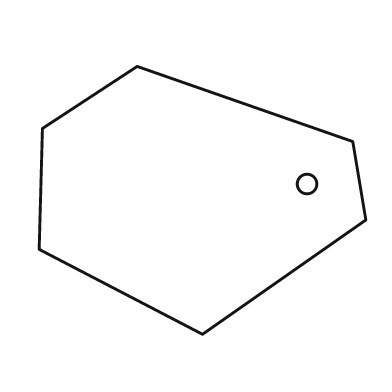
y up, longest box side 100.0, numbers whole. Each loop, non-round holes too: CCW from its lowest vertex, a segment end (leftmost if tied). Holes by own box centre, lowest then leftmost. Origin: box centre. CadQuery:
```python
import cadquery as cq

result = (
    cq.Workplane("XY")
    .moveTo(0.0, -41.0)
    .lineTo(50.0, -6.0)
    .lineTo(46.0, 18.0)
    .lineTo(-20.0, 41.0)
    .lineTo(-49.0, 22.0)
    .lineTo(-50.0, -15.0)
    .close()
    .moveTo(32.0, 5.0)
    .circle(3.0)
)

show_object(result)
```